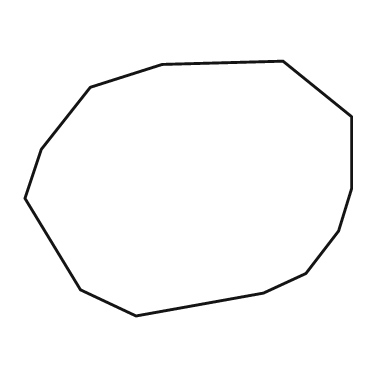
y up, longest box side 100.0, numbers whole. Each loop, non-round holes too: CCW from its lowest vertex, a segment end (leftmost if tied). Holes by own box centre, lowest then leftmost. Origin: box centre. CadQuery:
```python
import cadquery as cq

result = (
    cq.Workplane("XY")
    .moveTo(-16.0, -39.0)
    .lineTo(23.0, -32.0)
    .lineTo(36.0, -26.0)
    .lineTo(46.0, -13.0)
    .lineTo(50.0, 0.0)
    .lineTo(50.0, 22.0)
    .lineTo(29.0, 39.0)
    .lineTo(-8.0, 38.0)
    .lineTo(-30.0, 31.0)
    .lineTo(-45.0, 12.0)
    .lineTo(-50.0, -3.0)
    .lineTo(-33.0, -31.0)
    .close()
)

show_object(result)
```